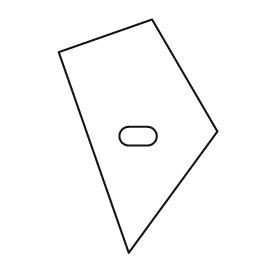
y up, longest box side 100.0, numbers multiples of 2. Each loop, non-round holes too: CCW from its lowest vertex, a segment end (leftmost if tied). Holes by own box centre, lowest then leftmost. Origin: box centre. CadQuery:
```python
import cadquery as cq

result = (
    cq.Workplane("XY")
    .moveTo(-4.0, -50.0)
    .lineTo(34.0, 2.0)
    .lineTo(6.0, 50.0)
    .lineTo(-34.0, 36.0)
    .close()
    .moveTo(-4.0, -4.0)
    .lineTo(4.0, -4.0)
    .threePointArc((8.0, 0.0), (4.0, 4.0))
    .lineTo(-4.0, 4.0)
    .threePointArc((-8.0, 0.0), (-4.0, -4.0))
    .close()
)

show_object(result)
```